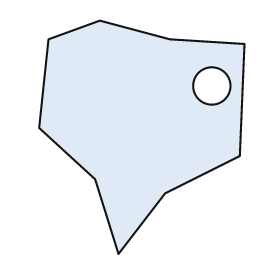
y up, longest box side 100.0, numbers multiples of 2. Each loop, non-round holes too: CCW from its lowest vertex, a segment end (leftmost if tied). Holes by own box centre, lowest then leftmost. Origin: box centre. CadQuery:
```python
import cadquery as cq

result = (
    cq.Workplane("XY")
    .moveTo(-10.0, -50.0)
    .lineTo(10.0, -24.0)
    .lineTo(42.0, -8.0)
    .lineTo(44.0, 40.0)
    .lineTo(12.0, 42.0)
    .lineTo(-18.0, 50.0)
    .lineTo(-40.0, 42.0)
    .lineTo(-44.0, 4.0)
    .lineTo(-20.0, -18.0)
    .close()
    .moveTo(30.0, 22.0)
    .circle(8.0)
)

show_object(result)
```